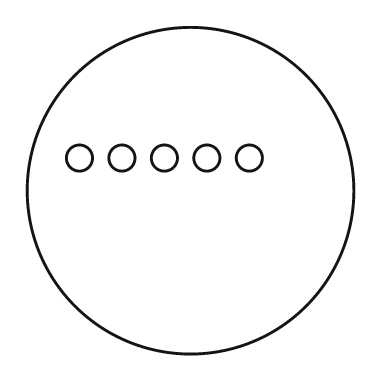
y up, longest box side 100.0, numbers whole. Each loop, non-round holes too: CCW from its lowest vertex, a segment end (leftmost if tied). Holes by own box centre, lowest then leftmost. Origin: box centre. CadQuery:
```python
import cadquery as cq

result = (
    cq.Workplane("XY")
    .moveTo(0.0, 0.0)
    .circle(50.0)
    .moveTo(-34.0, 10.0)
    .circle(4.0)
    .moveTo(-21.0, 10.0)
    .circle(4.0)
    .moveTo(-8.0, 10.0)
    .circle(4.0)
    .moveTo(5.0, 10.0)
    .circle(4.0)
    .moveTo(18.0, 10.0)
    .circle(4.0)
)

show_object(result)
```